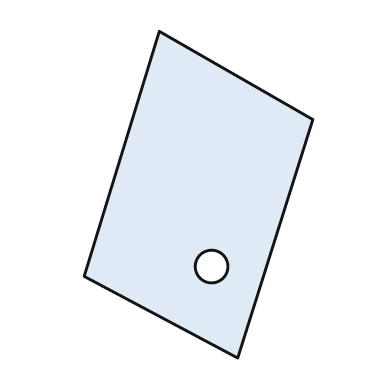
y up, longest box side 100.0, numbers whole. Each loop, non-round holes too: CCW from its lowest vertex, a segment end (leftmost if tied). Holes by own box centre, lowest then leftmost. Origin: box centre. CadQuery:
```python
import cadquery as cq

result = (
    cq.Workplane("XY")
    .moveTo(12.0, -50.0)
    .lineTo(35.0, 23.0)
    .lineTo(-12.0, 50.0)
    .lineTo(-35.0, -25.0)
    .close()
    .moveTo(4.0, -22.0)
    .circle(5.0)
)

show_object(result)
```